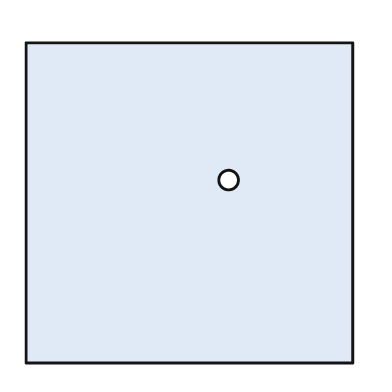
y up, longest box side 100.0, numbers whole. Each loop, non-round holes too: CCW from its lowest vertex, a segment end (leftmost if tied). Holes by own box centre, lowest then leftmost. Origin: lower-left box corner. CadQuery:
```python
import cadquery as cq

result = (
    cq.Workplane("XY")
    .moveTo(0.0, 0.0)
    .lineTo(100.0, 0.0)
    .lineTo(100.0, 98.0)
    .lineTo(0.0, 98.0)
    .close()
    .moveTo(62.0, 56.0)
    .circle(3.0)
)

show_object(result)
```